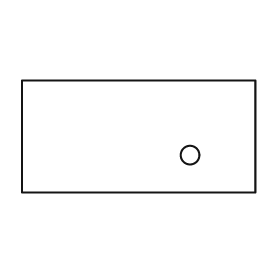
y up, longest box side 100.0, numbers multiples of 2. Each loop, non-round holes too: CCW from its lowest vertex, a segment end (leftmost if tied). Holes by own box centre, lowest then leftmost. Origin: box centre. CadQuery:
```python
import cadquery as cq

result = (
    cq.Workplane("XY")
    .moveTo(-50.0, -24.0)
    .lineTo(50.0, -24.0)
    .lineTo(50.0, 24.0)
    .lineTo(-50.0, 24.0)
    .close()
    .moveTo(22.0, -8.0)
    .circle(4.0)
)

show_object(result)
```